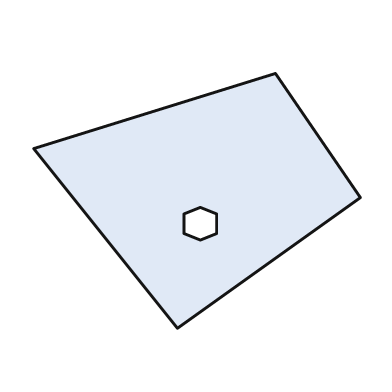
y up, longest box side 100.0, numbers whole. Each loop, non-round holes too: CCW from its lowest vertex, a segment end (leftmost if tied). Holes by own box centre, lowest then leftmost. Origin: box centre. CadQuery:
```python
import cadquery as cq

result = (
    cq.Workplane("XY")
    .moveTo(-6.0, -39.0)
    .lineTo(50.0, 1.0)
    .lineTo(24.0, 39.0)
    .lineTo(-50.0, 16.0)
    .close()
    .moveTo(1.0, -12.0)
    .lineTo(6.0, -10.0)
    .lineTo(6.0, -4.0)
    .lineTo(1.0, -2.0)
    .lineTo(-4.0, -4.0)
    .lineTo(-4.0, -10.0)
    .close()
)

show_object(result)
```